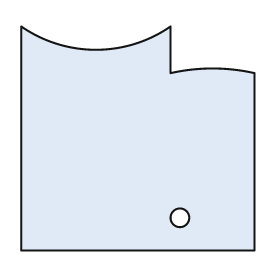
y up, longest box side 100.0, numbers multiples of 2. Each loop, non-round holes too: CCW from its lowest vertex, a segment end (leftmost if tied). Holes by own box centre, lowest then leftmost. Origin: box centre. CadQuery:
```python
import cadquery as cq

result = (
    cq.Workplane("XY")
    .moveTo(-50.0, -48.0)
    .lineTo(50.0, -48.0)
    .lineTo(50.0, 28.0)
    .threePointArc((32.0, 30.0), (14.0, 28.0))
    .lineTo(14.0, 48.0)
    .threePointArc((-18.0, 38.0), (-50.0, 48.0))
    .close()
    .moveTo(18.0, -34.0)
    .circle(4.0)
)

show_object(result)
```